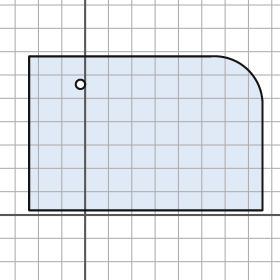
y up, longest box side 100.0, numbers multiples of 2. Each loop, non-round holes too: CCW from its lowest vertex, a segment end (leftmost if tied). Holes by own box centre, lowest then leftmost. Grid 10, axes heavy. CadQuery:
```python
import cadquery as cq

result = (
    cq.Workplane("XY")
    .moveTo(-24.0, 2.0)
    .lineTo(76.0, 2.0)
    .lineTo(76.0, 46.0)
    .threePointArc((70.0, 62.0), (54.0, 68.0))
    .lineTo(-24.0, 68.0)
    .close()
    .moveTo(-2.0, 56.0)
    .circle(2.0)
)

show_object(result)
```